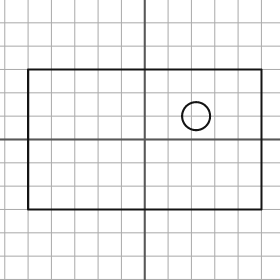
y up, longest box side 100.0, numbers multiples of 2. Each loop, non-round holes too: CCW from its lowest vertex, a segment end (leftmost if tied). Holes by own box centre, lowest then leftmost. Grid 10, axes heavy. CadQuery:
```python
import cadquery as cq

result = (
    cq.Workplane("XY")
    .moveTo(-50.0, -30.0)
    .lineTo(50.0, -30.0)
    .lineTo(50.0, 30.0)
    .lineTo(-50.0, 30.0)
    .close()
    .moveTo(22.0, 10.0)
    .circle(6.0)
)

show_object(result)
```